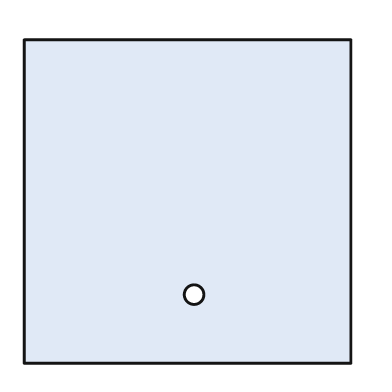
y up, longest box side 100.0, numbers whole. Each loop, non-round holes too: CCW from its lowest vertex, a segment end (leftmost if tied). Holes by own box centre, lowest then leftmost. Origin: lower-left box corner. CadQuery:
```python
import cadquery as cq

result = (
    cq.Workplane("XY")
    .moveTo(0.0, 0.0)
    .lineTo(100.0, 0.0)
    .lineTo(100.0, 99.0)
    .lineTo(0.0, 99.0)
    .close()
    .moveTo(52.0, 21.0)
    .circle(3.0)
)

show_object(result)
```